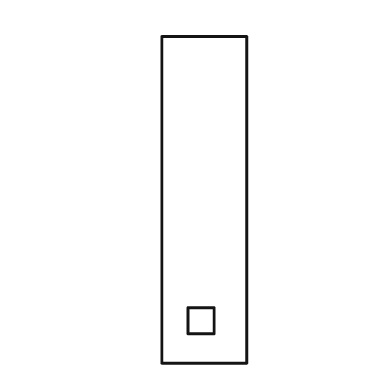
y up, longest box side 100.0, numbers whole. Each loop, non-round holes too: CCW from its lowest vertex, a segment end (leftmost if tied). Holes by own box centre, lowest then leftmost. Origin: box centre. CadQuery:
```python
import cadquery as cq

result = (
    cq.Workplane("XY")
    .moveTo(-13.0, -50.0)
    .lineTo(13.0, -50.0)
    .lineTo(13.0, 50.0)
    .lineTo(-13.0, 50.0)
    .close()
    .moveTo(-5.0, -41.0)
    .lineTo(3.0, -41.0)
    .lineTo(3.0, -33.0)
    .lineTo(-5.0, -33.0)
    .close()
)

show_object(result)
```